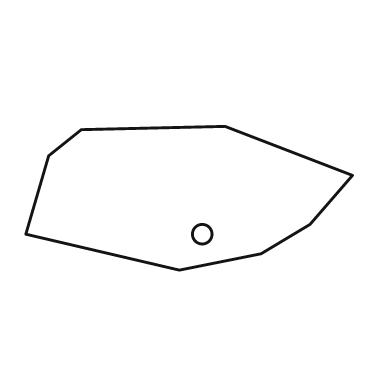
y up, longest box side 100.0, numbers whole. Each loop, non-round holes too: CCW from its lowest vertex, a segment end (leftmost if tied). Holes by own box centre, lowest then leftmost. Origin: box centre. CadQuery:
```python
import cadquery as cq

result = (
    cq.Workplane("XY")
    .moveTo(-3.0, -22.0)
    .lineTo(22.0, -17.0)
    .lineTo(37.0, -8.0)
    .lineTo(50.0, 7.0)
    .lineTo(11.0, 22.0)
    .lineTo(-33.0, 21.0)
    .lineTo(-43.0, 13.0)
    .lineTo(-50.0, -11.0)
    .close()
    .moveTo(4.0, -11.0)
    .circle(3.0)
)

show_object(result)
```